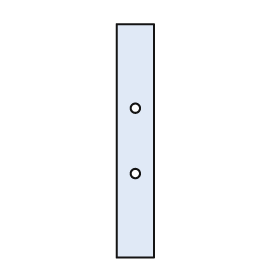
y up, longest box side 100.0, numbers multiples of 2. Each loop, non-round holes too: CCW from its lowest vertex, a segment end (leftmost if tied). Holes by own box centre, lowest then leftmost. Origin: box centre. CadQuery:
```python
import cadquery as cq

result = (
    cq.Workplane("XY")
    .moveTo(-8.0, -50.0)
    .lineTo(8.0, -50.0)
    .lineTo(8.0, 50.0)
    .lineTo(-8.0, 50.0)
    .close()
    .moveTo(0.0, -14.0)
    .circle(2.0)
    .moveTo(0.0, 14.0)
    .circle(2.0)
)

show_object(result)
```